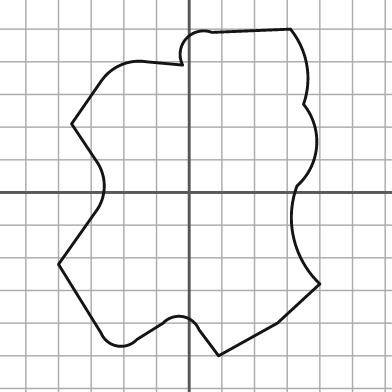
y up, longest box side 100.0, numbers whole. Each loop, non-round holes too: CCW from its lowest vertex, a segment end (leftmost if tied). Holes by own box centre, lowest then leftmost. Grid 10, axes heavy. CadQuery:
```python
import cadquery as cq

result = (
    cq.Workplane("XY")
    .moveTo(9.0, -50.0)
    .lineTo(27.0, -40.0)
    .lineTo(40.0, -28.0)
    .threePointArc((32.0, -14.0), (33.0, 2.0))
    .threePointArc((39.0, 14.0), (35.0, 27.0))
    .threePointArc((36.0, 39.0), (31.0, 50.0))
    .lineTo(7.0, 49.0)
    .threePointArc((-1.0, 47.0), (-2.0, 39.0))
    .lineTo(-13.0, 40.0)
    .threePointArc((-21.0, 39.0), (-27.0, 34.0))
    .lineTo(-36.0, 21.0)
    .lineTo(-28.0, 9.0)
    .threePointArc((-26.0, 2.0), (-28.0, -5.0))
    .lineTo(-40.0, -22.0)
    .lineTo(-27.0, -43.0)
    .threePointArc((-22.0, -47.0), (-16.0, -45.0))
    .lineTo(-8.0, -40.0)
    .threePointArc((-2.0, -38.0), (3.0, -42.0))
    .close()
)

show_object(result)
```